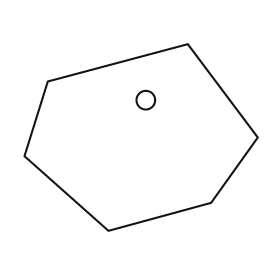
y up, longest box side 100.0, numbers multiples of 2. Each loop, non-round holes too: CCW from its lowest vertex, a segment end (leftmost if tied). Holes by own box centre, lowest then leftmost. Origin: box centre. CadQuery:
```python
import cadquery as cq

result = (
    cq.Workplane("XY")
    .moveTo(-14.0, -40.0)
    .lineTo(30.0, -28.0)
    .lineTo(50.0, 0.0)
    .lineTo(20.0, 40.0)
    .lineTo(-40.0, 24.0)
    .lineTo(-50.0, -8.0)
    .close()
    .moveTo(2.0, 16.0)
    .circle(4.0)
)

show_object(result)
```